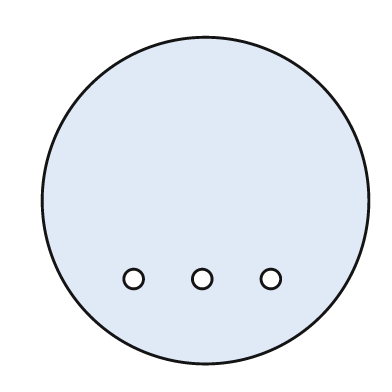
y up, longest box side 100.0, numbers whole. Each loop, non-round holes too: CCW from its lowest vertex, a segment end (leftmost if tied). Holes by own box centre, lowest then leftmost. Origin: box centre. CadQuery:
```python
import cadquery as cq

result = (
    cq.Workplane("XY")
    .moveTo(0.0, 0.0)
    .circle(50.0)
    .moveTo(-22.0, -24.0)
    .circle(3.0)
    .moveTo(-1.0, -24.0)
    .circle(3.0)
    .moveTo(20.0, -24.0)
    .circle(3.0)
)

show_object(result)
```